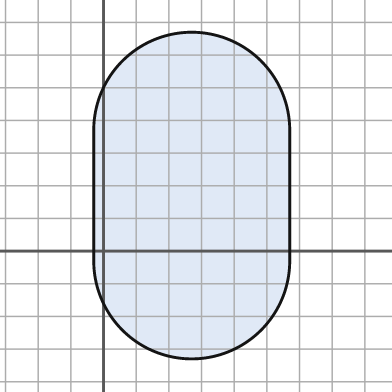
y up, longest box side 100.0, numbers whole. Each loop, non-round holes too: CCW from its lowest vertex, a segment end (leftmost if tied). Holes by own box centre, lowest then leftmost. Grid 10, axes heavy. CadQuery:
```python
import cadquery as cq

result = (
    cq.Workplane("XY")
    .moveTo(-3.0, -3.0)
    .threePointArc((27.0, -33.0), (57.0, -3.0))
    .lineTo(57.0, 37.0)
    .threePointArc((27.0, 67.0), (-3.0, 37.0))
    .close()
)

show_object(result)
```